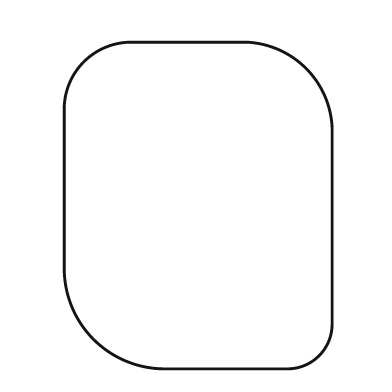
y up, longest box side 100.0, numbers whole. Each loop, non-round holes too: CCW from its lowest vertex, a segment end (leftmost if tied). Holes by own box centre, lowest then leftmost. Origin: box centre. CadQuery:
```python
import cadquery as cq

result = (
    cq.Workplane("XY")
    .moveTo(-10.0, -50.0)
    .lineTo(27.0, -50.0)
    .threePointArc((37.0, -46.0), (41.0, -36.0))
    .lineTo(41.0, 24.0)
    .threePointArc((33.0, 42.0), (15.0, 50.0))
    .lineTo(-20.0, 50.0)
    .threePointArc((-35.0, 44.0), (-41.0, 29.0))
    .lineTo(-41.0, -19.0)
    .threePointArc((-32.0, -41.0), (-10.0, -50.0))
    .close()
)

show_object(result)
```